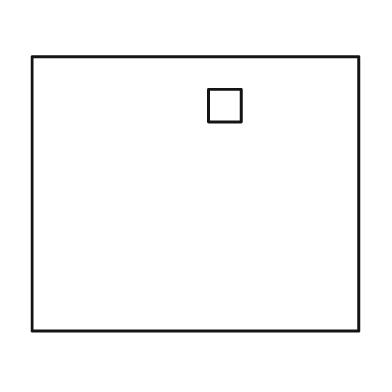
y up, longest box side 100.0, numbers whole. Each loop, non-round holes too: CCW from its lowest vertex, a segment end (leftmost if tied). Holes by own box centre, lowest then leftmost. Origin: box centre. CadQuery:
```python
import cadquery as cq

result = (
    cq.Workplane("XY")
    .moveTo(-50.0, -42.0)
    .lineTo(50.0, -42.0)
    .lineTo(50.0, 42.0)
    .lineTo(-50.0, 42.0)
    .close()
    .moveTo(4.0, 22.0)
    .lineTo(14.0, 22.0)
    .lineTo(14.0, 32.0)
    .lineTo(4.0, 32.0)
    .close()
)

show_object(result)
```